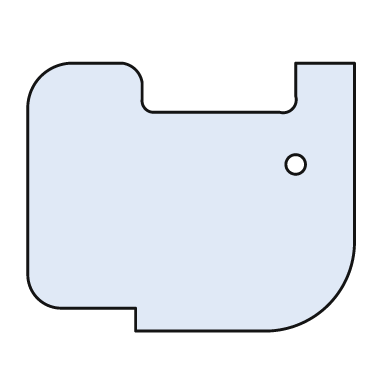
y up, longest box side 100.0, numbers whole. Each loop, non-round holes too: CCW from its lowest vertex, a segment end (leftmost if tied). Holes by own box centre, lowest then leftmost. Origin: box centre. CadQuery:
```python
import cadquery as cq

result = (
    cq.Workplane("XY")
    .moveTo(-17.0, -41.0)
    .lineTo(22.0, -41.0)
    .threePointArc((42.0, -33.0), (50.0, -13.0))
    .lineTo(50.0, 41.0)
    .lineTo(32.0, 41.0)
    .lineTo(32.0, 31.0)
    .threePointArc((31.0, 27.0), (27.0, 26.0))
    .lineTo(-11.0, 26.0)
    .threePointArc((-14.0, 27.0), (-15.0, 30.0))
    .lineTo(-15.0, 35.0)
    .threePointArc((-17.0, 39.0), (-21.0, 41.0))
    .lineTo(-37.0, 41.0)
    .threePointArc((-46.0, 37.0), (-50.0, 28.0))
    .lineTo(-50.0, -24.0)
    .threePointArc((-47.0, -31.0), (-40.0, -34.0))
    .lineTo(-17.0, -34.0)
    .close()
    .moveTo(32.0, 10.0)
    .circle(3.0)
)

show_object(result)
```